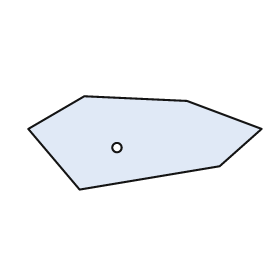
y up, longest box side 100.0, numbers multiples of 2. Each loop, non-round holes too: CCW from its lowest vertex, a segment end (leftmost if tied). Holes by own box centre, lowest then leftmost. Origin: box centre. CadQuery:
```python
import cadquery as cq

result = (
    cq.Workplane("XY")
    .moveTo(-28.0, -20.0)
    .lineTo(32.0, -10.0)
    .lineTo(50.0, 6.0)
    .lineTo(18.0, 18.0)
    .lineTo(-26.0, 20.0)
    .lineTo(-50.0, 6.0)
    .close()
    .moveTo(-12.0, -2.0)
    .circle(2.0)
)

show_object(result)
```